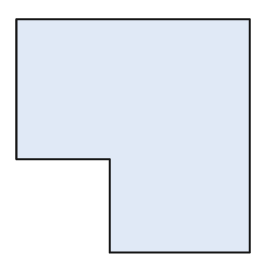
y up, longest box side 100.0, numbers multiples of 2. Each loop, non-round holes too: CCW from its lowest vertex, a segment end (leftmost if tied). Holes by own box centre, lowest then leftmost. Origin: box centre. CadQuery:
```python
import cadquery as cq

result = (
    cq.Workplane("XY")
    .moveTo(-10.0, -50.0)
    .lineTo(50.0, -50.0)
    .lineTo(50.0, 50.0)
    .lineTo(-50.0, 50.0)
    .lineTo(-50.0, -10.0)
    .lineTo(-10.0, -10.0)
    .close()
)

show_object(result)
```